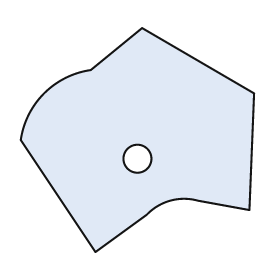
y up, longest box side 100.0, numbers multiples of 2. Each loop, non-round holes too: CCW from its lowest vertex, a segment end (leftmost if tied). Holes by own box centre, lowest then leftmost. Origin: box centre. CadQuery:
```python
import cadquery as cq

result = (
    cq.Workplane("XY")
    .moveTo(-18.0, -48.0)
    .lineTo(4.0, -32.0)
    .threePointArc((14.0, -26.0), (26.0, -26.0))
    .lineTo(48.0, -30.0)
    .lineTo(50.0, 20.0)
    .lineTo(2.0, 48.0)
    .lineTo(-20.0, 30.0)
    .threePointArc((-40.0, 20.0), (-50.0, 0.0))
    .close()
    .moveTo(0.0, -8.0)
    .circle(6.0)
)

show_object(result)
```